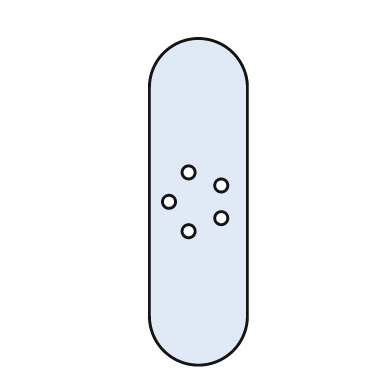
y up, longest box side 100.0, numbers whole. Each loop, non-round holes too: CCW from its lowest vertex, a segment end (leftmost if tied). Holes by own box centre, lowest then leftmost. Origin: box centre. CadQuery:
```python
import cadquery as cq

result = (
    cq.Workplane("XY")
    .moveTo(-15.0, -35.0)
    .threePointArc((0.0, -50.0), (15.0, -35.0))
    .lineTo(15.0, 35.0)
    .threePointArc((0.0, 50.0), (-15.0, 35.0))
    .close()
    .moveTo(-3.0, -9.0)
    .circle(2.0)
    .moveTo(7.0, -5.0)
    .circle(2.0)
    .moveTo(-9.0, 0.0)
    .circle(2.0)
    .moveTo(7.0, 5.0)
    .circle(2.0)
    .moveTo(-3.0, 9.0)
    .circle(2.0)
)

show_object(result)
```